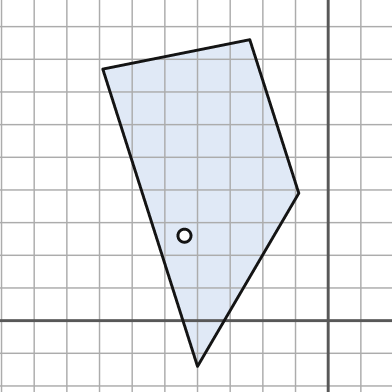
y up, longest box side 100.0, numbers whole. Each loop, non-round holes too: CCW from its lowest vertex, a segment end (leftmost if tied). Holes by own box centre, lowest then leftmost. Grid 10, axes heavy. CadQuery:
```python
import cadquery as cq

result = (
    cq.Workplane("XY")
    .moveTo(-40.0, -14.0)
    .lineTo(-9.0, 39.0)
    .lineTo(-24.0, 86.0)
    .lineTo(-69.0, 77.0)
    .close()
    .moveTo(-44.0, 26.0)
    .circle(2.0)
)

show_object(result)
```